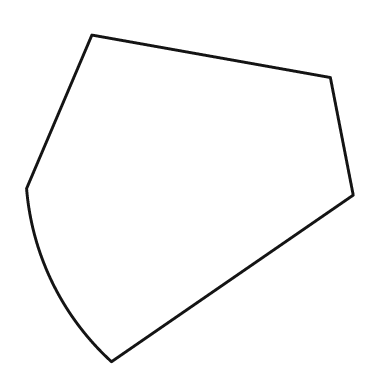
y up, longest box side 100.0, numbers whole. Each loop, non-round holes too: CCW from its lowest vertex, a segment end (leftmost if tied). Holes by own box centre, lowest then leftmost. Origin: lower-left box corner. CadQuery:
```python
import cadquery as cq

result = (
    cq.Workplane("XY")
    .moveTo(26.0, 0.0)
    .lineTo(100.0, 51.0)
    .lineTo(93.0, 87.0)
    .lineTo(20.0, 100.0)
    .lineTo(0.0, 53.0)
    .threePointArc((8.0, 24.0), (26.0, 0.0))
    .close()
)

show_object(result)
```